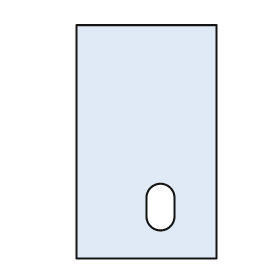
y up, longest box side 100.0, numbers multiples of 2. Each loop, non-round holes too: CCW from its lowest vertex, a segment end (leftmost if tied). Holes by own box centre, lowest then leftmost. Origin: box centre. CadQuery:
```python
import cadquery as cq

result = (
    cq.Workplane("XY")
    .moveTo(-30.0, -50.0)
    .lineTo(30.0, -50.0)
    .lineTo(30.0, 50.0)
    .lineTo(-30.0, 50.0)
    .close()
    .moveTo(0.0, -32.0)
    .threePointArc((6.0, -38.0), (12.0, -32.0))
    .lineTo(12.0, -24.0)
    .threePointArc((6.0, -18.0), (0.0, -24.0))
    .close()
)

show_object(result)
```